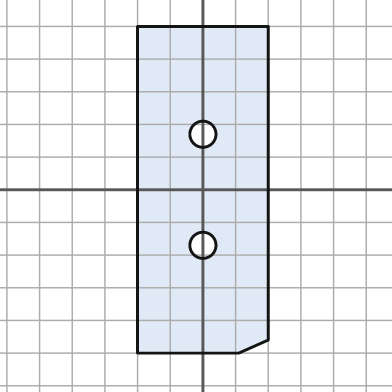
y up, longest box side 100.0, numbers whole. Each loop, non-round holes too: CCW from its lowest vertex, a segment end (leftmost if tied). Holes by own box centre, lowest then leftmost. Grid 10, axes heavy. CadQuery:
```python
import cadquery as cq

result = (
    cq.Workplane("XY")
    .moveTo(-20.0, -50.0)
    .lineTo(11.0, -50.0)
    .lineTo(20.0, -46.0)
    .lineTo(20.0, 50.0)
    .lineTo(-20.0, 50.0)
    .close()
    .moveTo(0.0, -17.0)
    .circle(4.0)
    .moveTo(0.0, 17.0)
    .circle(4.0)
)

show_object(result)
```